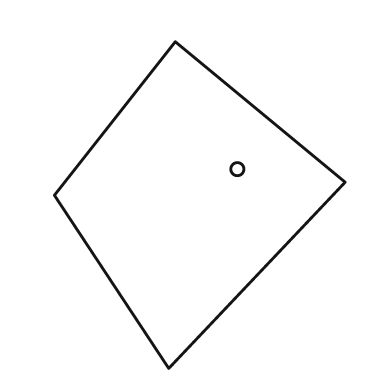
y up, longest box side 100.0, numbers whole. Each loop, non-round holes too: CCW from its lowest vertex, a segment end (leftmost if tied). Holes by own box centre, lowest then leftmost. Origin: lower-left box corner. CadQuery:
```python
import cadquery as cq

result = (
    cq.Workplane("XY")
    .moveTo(35.0, 0.0)
    .lineTo(89.0, 57.0)
    .lineTo(37.0, 100.0)
    .lineTo(0.0, 53.0)
    .close()
    .moveTo(56.0, 61.0)
    .circle(2.0)
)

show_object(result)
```